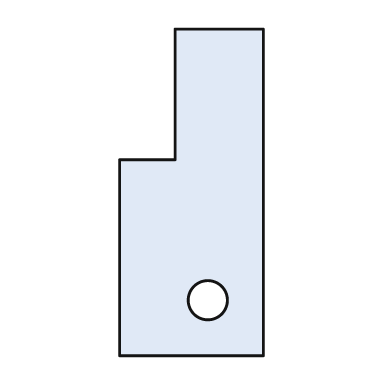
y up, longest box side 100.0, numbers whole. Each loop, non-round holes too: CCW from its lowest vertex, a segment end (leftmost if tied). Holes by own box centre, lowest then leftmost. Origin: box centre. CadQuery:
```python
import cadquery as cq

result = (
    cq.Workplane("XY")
    .moveTo(-22.0, -50.0)
    .lineTo(22.0, -50.0)
    .lineTo(22.0, 50.0)
    .lineTo(-5.0, 50.0)
    .lineTo(-5.0, 10.0)
    .lineTo(-22.0, 10.0)
    .close()
    .moveTo(5.0, -33.0)
    .circle(6.0)
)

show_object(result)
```